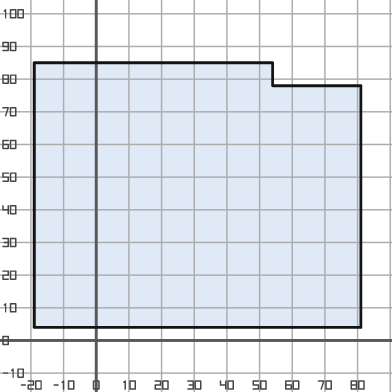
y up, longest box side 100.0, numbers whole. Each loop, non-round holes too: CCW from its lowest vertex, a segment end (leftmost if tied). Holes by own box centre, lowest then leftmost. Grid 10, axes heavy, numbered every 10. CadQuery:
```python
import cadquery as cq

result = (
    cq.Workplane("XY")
    .moveTo(-19.0, 4.0)
    .lineTo(81.0, 4.0)
    .lineTo(81.0, 78.0)
    .lineTo(54.0, 78.0)
    .lineTo(54.0, 85.0)
    .lineTo(-19.0, 85.0)
    .close()
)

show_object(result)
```